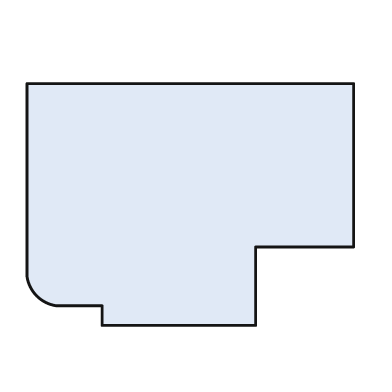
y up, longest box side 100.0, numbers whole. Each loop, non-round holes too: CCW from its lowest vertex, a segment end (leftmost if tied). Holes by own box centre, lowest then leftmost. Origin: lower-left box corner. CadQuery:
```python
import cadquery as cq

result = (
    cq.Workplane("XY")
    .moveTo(23.0, 0.0)
    .lineTo(70.0, 0.0)
    .lineTo(70.0, 24.0)
    .lineTo(100.0, 24.0)
    .lineTo(100.0, 74.0)
    .lineTo(0.0, 74.0)
    .lineTo(0.0, 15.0)
    .threePointArc((3.0, 9.0), (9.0, 6.0))
    .lineTo(23.0, 6.0)
    .close()
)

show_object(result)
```